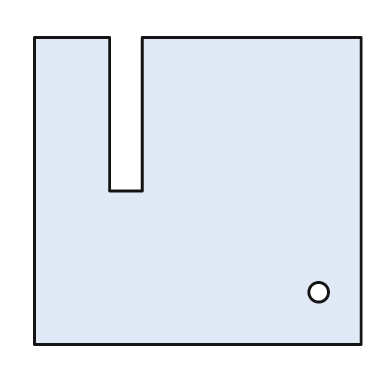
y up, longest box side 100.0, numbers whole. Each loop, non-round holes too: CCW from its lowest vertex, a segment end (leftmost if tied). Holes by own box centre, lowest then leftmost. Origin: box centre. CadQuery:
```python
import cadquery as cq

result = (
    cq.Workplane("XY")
    .moveTo(-50.0, -47.0)
    .lineTo(50.0, -47.0)
    .lineTo(50.0, 47.0)
    .lineTo(-17.0, 47.0)
    .lineTo(-17.0, 0.0)
    .lineTo(-27.0, 0.0)
    .lineTo(-27.0, 47.0)
    .lineTo(-50.0, 47.0)
    .close()
    .moveTo(37.0, -31.0)
    .circle(3.0)
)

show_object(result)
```